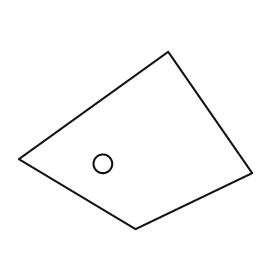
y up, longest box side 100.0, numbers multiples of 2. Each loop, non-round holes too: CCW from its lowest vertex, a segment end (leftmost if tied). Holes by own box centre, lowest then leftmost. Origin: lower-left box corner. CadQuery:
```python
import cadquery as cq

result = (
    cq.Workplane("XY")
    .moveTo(50.0, 0.0)
    .lineTo(100.0, 24.0)
    .lineTo(64.0, 76.0)
    .lineTo(0.0, 30.0)
    .close()
    .moveTo(36.0, 28.0)
    .circle(4.0)
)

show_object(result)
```